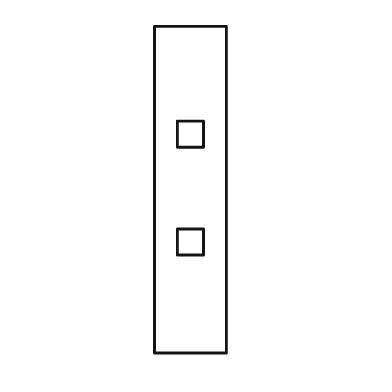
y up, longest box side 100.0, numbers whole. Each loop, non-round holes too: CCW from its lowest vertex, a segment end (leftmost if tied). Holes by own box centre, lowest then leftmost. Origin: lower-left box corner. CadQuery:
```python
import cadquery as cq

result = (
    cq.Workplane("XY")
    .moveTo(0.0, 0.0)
    .lineTo(22.0, 0.0)
    .lineTo(22.0, 100.0)
    .lineTo(0.0, 100.0)
    .close()
    .moveTo(7.0, 30.0)
    .lineTo(15.0, 30.0)
    .lineTo(15.0, 38.0)
    .lineTo(7.0, 38.0)
    .close()
    .moveTo(7.0, 63.0)
    .lineTo(15.0, 63.0)
    .lineTo(15.0, 71.0)
    .lineTo(7.0, 71.0)
    .close()
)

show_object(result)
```